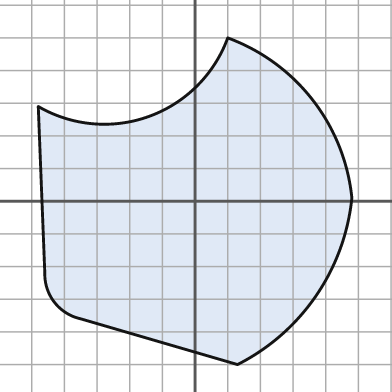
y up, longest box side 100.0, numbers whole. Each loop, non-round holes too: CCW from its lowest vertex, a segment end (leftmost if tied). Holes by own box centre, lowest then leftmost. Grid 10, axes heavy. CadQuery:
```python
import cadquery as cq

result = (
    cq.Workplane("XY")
    .moveTo(13.0, -50.0)
    .threePointArc((37.0, -29.0), (48.0, 1.0))
    .threePointArc((36.0, 31.0), (10.0, 50.0))
    .threePointArc((-14.0, 26.0), (-48.0, 29.0))
    .lineTo(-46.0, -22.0)
    .threePointArc((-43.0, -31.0), (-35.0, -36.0))
    .close()
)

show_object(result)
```